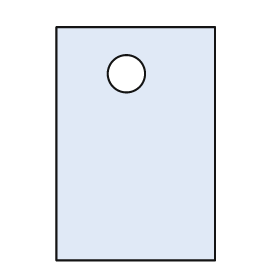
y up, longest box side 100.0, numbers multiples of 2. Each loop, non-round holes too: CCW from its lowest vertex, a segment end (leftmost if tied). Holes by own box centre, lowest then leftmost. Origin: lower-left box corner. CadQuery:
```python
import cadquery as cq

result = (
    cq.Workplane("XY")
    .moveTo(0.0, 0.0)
    .lineTo(68.0, 0.0)
    .lineTo(68.0, 100.0)
    .lineTo(0.0, 100.0)
    .close()
    .moveTo(30.0, 80.0)
    .circle(8.0)
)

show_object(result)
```